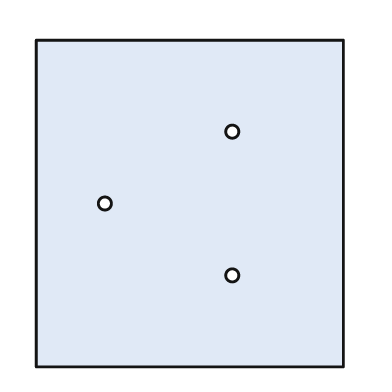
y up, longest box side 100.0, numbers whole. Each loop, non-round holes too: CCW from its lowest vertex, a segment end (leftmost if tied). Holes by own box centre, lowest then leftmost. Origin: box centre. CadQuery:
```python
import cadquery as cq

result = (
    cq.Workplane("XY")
    .moveTo(-47.0, -50.0)
    .lineTo(47.0, -50.0)
    .lineTo(47.0, 50.0)
    .lineTo(-47.0, 50.0)
    .close()
    .moveTo(13.0, -22.0)
    .circle(2.0)
    .moveTo(-26.0, 0.0)
    .circle(2.0)
    .moveTo(13.0, 22.0)
    .circle(2.0)
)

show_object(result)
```